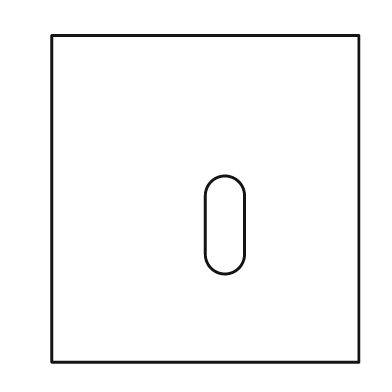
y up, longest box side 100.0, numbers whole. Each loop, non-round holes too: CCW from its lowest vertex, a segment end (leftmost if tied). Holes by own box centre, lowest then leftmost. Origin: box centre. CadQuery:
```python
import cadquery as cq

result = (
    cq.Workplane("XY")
    .moveTo(-47.0, -50.0)
    .lineTo(47.0, -50.0)
    .lineTo(47.0, 50.0)
    .lineTo(-47.0, 50.0)
    .close()
    .moveTo(0.0, -17.0)
    .threePointArc((6.0, -23.0), (12.0, -17.0))
    .lineTo(12.0, 1.0)
    .threePointArc((6.0, 7.0), (0.0, 1.0))
    .close()
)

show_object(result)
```